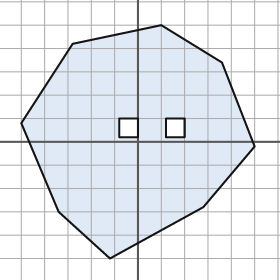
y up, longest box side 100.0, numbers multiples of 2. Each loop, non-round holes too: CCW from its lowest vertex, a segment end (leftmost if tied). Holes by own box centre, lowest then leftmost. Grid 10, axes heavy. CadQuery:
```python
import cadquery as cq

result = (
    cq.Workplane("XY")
    .moveTo(-12.0, -50.0)
    .lineTo(28.0, -28.0)
    .lineTo(50.0, -2.0)
    .lineTo(36.0, 34.0)
    .lineTo(10.0, 50.0)
    .lineTo(-28.0, 42.0)
    .lineTo(-50.0, 8.0)
    .lineTo(-34.0, -30.0)
    .close()
    .moveTo(-8.0, 2.0)
    .lineTo(0.0, 2.0)
    .lineTo(0.0, 10.0)
    .lineTo(-8.0, 10.0)
    .close()
    .moveTo(12.0, 2.0)
    .lineTo(20.0, 2.0)
    .lineTo(20.0, 10.0)
    .lineTo(12.0, 10.0)
    .close()
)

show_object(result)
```